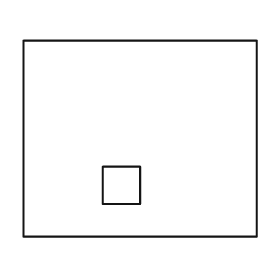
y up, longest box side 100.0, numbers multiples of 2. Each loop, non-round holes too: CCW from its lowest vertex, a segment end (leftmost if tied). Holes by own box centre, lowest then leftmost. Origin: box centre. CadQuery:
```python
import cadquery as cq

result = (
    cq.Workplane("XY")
    .moveTo(-50.0, -42.0)
    .lineTo(50.0, -42.0)
    .lineTo(50.0, 42.0)
    .lineTo(-50.0, 42.0)
    .close()
    .moveTo(-16.0, -28.0)
    .lineTo(0.0, -28.0)
    .lineTo(0.0, -12.0)
    .lineTo(-16.0, -12.0)
    .close()
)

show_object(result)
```